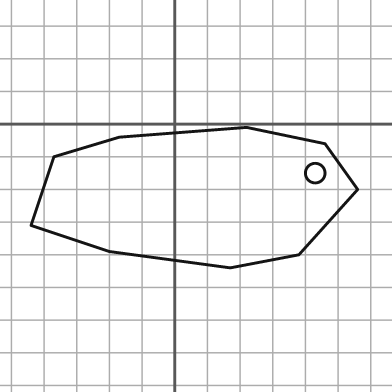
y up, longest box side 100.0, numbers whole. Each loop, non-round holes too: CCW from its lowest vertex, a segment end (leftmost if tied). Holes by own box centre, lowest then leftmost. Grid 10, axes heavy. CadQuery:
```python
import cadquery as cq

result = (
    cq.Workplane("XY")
    .moveTo(17.0, -44.0)
    .lineTo(38.0, -40.0)
    .lineTo(56.0, -20.0)
    .lineTo(46.0, -6.0)
    .lineTo(22.0, -1.0)
    .lineTo(-17.0, -4.0)
    .lineTo(-37.0, -10.0)
    .lineTo(-44.0, -31.0)
    .lineTo(-20.0, -39.0)
    .close()
    .moveTo(43.0, -15.0)
    .circle(3.0)
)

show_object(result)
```